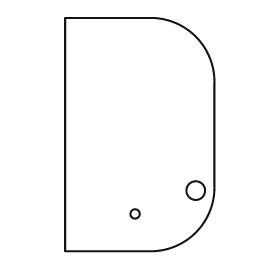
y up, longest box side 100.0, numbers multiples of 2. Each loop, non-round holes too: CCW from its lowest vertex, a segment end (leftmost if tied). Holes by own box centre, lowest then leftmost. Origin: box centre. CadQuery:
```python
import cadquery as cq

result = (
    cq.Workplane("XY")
    .moveTo(-32.0, -50.0)
    .lineTo(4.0, -50.0)
    .threePointArc((24.0, -42.0), (32.0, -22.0))
    .lineTo(32.0, 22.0)
    .threePointArc((24.0, 42.0), (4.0, 50.0))
    .lineTo(-32.0, 50.0)
    .close()
    .moveTo(-2.0, -34.0)
    .circle(2.0)
    .moveTo(24.0, -24.0)
    .circle(4.0)
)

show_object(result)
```